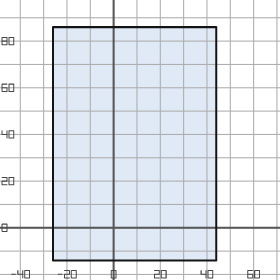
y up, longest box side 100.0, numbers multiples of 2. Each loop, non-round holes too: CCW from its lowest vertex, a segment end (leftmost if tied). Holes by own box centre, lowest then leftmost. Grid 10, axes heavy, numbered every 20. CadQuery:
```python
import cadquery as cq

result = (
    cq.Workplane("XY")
    .moveTo(-26.0, -14.0)
    .lineTo(44.0, -14.0)
    .lineTo(44.0, 86.0)
    .lineTo(-26.0, 86.0)
    .close()
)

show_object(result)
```